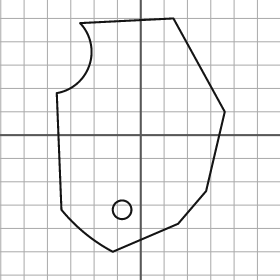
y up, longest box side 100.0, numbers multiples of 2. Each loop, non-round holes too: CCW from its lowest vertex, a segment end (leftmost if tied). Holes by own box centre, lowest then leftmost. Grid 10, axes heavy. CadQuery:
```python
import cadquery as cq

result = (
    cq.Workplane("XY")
    .moveTo(-12.0, -50.0)
    .lineTo(16.0, -38.0)
    .lineTo(28.0, -24.0)
    .lineTo(36.0, 10.0)
    .lineTo(14.0, 50.0)
    .lineTo(-26.0, 48.0)
    .threePointArc((-22.0, 30.0), (-36.0, 18.0))
    .lineTo(-34.0, -32.0)
    .threePointArc((-24.0, -42.0), (-12.0, -50.0))
    .close()
    .moveTo(-8.0, -32.0)
    .circle(4.0)
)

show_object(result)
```